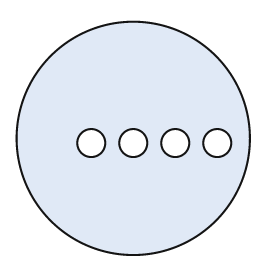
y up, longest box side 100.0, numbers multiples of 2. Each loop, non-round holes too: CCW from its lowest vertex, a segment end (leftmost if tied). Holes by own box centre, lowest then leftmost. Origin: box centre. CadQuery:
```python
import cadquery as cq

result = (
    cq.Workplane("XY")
    .moveTo(0.0, 0.0)
    .circle(50.0)
    .moveTo(-18.0, -2.0)
    .circle(6.0)
    .moveTo(0.0, -2.0)
    .circle(6.0)
    .moveTo(18.0, -2.0)
    .circle(6.0)
    .moveTo(36.0, -2.0)
    .circle(6.0)
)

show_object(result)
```